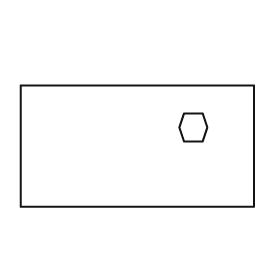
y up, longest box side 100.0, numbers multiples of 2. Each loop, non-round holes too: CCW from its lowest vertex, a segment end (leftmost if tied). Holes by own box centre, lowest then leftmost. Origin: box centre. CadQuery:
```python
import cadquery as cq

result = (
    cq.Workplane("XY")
    .moveTo(-50.0, -26.0)
    .lineTo(50.0, -26.0)
    .lineTo(50.0, 26.0)
    .lineTo(-50.0, 26.0)
    .close()
    .moveTo(20.0, 2.0)
    .lineTo(28.0, 2.0)
    .lineTo(30.0, 8.0)
    .lineTo(28.0, 14.0)
    .lineTo(20.0, 14.0)
    .lineTo(18.0, 8.0)
    .close()
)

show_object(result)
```